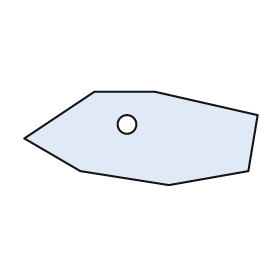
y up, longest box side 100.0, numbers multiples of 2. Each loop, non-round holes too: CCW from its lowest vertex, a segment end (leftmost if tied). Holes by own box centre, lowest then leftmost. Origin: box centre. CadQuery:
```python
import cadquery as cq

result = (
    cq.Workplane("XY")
    .moveTo(12.0, -20.0)
    .lineTo(46.0, -14.0)
    .lineTo(50.0, 10.0)
    .lineTo(6.0, 20.0)
    .lineTo(-20.0, 20.0)
    .lineTo(-50.0, 0.0)
    .lineTo(-26.0, -14.0)
    .close()
    .moveTo(-6.0, 6.0)
    .circle(4.0)
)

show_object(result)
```